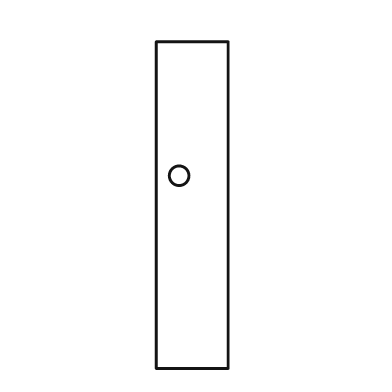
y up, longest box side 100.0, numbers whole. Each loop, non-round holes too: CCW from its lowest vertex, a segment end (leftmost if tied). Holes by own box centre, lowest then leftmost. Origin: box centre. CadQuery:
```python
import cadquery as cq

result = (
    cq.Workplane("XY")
    .moveTo(-11.0, -50.0)
    .lineTo(11.0, -50.0)
    .lineTo(11.0, 50.0)
    .lineTo(-11.0, 50.0)
    .close()
    .moveTo(-4.0, 9.0)
    .circle(3.0)
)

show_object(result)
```